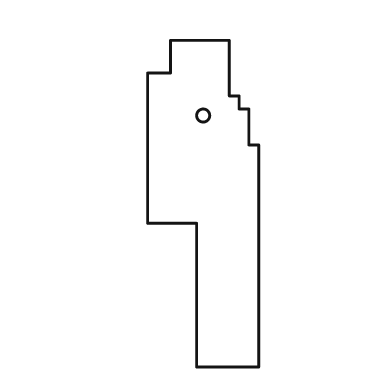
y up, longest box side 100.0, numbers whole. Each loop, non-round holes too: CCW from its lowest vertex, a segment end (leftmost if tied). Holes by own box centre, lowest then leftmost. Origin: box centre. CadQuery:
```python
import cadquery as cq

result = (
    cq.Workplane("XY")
    .moveTo(-2.0, -50.0)
    .lineTo(17.0, -50.0)
    .lineTo(17.0, 18.0)
    .lineTo(14.0, 18.0)
    .lineTo(14.0, 29.0)
    .lineTo(11.0, 29.0)
    .lineTo(11.0, 33.0)
    .lineTo(8.0, 33.0)
    .lineTo(8.0, 50.0)
    .lineTo(-10.0, 50.0)
    .lineTo(-10.0, 40.0)
    .lineTo(-17.0, 40.0)
    .lineTo(-17.0, -6.0)
    .lineTo(-2.0, -6.0)
    .close()
    .moveTo(0.0, 27.0)
    .circle(2.0)
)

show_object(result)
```